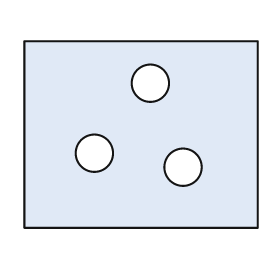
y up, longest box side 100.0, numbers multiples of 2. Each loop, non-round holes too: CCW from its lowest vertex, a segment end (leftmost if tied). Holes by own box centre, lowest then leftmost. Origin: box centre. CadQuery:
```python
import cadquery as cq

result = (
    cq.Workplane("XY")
    .moveTo(-50.0, -40.0)
    .lineTo(50.0, -40.0)
    .lineTo(50.0, 40.0)
    .lineTo(-50.0, 40.0)
    .close()
    .moveTo(18.0, -14.0)
    .circle(8.0)
    .moveTo(-20.0, -8.0)
    .circle(8.0)
    .moveTo(4.0, 22.0)
    .circle(8.0)
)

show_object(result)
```